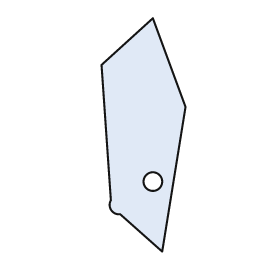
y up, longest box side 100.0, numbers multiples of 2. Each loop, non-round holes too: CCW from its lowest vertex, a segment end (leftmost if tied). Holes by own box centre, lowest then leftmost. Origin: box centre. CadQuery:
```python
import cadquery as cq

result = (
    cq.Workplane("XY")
    .moveTo(8.0, -50.0)
    .lineTo(18.0, 12.0)
    .lineTo(4.0, 50.0)
    .lineTo(-18.0, 30.0)
    .lineTo(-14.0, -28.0)
    .threePointArc((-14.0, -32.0), (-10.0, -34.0))
    .close()
    .moveTo(4.0, -20.0)
    .circle(4.0)
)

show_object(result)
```